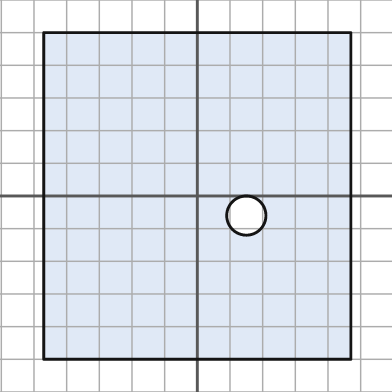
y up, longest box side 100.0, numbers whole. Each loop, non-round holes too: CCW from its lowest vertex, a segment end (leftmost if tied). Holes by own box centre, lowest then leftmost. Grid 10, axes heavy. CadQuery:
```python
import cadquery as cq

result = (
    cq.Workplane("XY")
    .moveTo(-47.0, -50.0)
    .lineTo(47.0, -50.0)
    .lineTo(47.0, 50.0)
    .lineTo(-47.0, 50.0)
    .close()
    .moveTo(15.0, -6.0)
    .circle(6.0)
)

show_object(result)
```